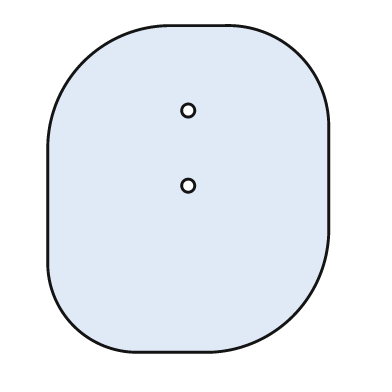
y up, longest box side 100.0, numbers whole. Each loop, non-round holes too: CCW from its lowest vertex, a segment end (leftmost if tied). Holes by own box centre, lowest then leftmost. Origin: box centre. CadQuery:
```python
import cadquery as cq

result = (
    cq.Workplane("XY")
    .moveTo(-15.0, -50.0)
    .lineTo(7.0, -50.0)
    .threePointArc((32.0, -39.0), (43.0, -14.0))
    .lineTo(43.0, 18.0)
    .threePointArc((34.0, 41.0), (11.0, 50.0))
    .lineTo(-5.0, 50.0)
    .threePointArc((-32.0, 39.0), (-43.0, 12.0))
    .lineTo(-43.0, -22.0)
    .threePointArc((-35.0, -42.0), (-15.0, -50.0))
    .close()
    .moveTo(0.0, 1.0)
    .circle(2.0)
    .moveTo(0.0, 24.0)
    .circle(2.0)
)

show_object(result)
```